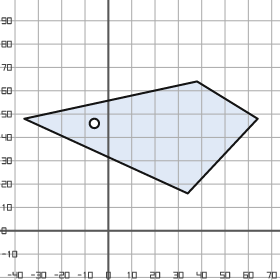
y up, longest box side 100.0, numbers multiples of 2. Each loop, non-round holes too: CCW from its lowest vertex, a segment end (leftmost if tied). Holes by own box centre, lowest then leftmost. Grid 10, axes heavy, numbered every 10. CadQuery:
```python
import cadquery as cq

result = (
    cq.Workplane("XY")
    .moveTo(34.0, 16.0)
    .lineTo(64.0, 48.0)
    .lineTo(38.0, 64.0)
    .lineTo(-36.0, 48.0)
    .close()
    .moveTo(-6.0, 46.0)
    .circle(2.0)
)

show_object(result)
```